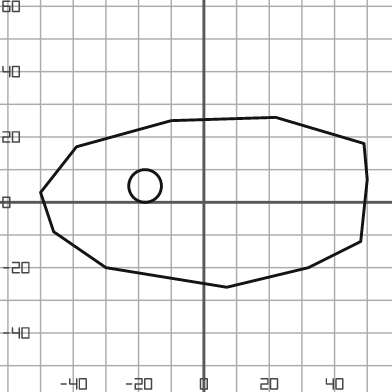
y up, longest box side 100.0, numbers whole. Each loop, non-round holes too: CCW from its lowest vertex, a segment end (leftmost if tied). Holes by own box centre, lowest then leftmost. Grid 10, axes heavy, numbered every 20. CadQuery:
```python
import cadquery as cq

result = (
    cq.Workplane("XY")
    .moveTo(7.0, -26.0)
    .lineTo(32.0, -20.0)
    .lineTo(48.0, -12.0)
    .lineTo(50.0, 7.0)
    .lineTo(49.0, 18.0)
    .lineTo(22.0, 26.0)
    .lineTo(-10.0, 25.0)
    .lineTo(-39.0, 17.0)
    .lineTo(-50.0, 3.0)
    .lineTo(-46.0, -9.0)
    .lineTo(-30.0, -20.0)
    .close()
    .moveTo(-18.0, 5.0)
    .circle(5.0)
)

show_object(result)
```